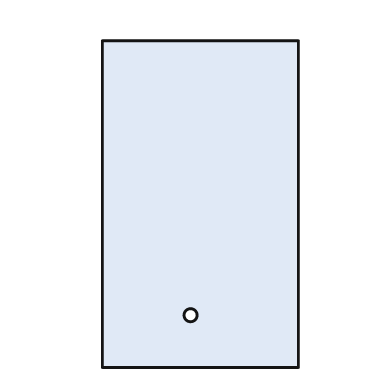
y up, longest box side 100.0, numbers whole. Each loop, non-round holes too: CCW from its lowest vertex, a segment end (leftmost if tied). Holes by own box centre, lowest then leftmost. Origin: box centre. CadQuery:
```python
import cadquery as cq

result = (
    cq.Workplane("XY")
    .moveTo(-30.0, -50.0)
    .lineTo(30.0, -50.0)
    .lineTo(30.0, 50.0)
    .lineTo(-30.0, 50.0)
    .close()
    .moveTo(-3.0, -34.0)
    .circle(2.0)
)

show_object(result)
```